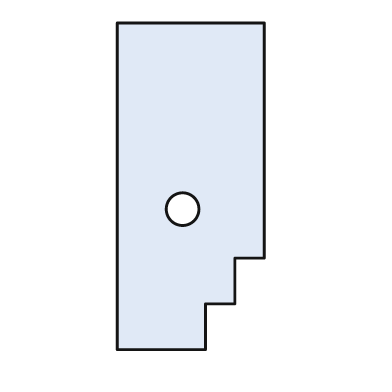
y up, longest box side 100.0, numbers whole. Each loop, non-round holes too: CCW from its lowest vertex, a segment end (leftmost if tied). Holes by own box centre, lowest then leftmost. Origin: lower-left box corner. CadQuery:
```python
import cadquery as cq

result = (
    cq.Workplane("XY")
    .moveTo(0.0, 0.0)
    .lineTo(27.0, 0.0)
    .lineTo(27.0, 14.0)
    .lineTo(36.0, 14.0)
    .lineTo(36.0, 28.0)
    .lineTo(45.0, 28.0)
    .lineTo(45.0, 100.0)
    .lineTo(0.0, 100.0)
    .close()
    .moveTo(20.0, 43.0)
    .circle(5.0)
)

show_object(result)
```